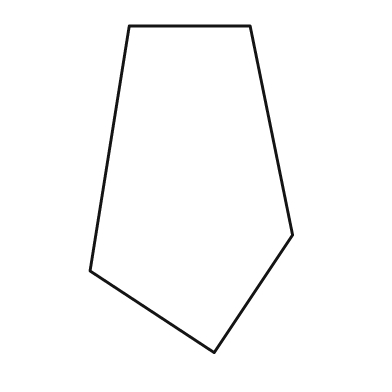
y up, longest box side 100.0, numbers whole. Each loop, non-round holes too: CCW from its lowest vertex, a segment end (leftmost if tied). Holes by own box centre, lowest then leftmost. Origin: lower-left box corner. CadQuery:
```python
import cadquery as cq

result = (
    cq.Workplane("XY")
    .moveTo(38.0, 0.0)
    .lineTo(62.0, 36.0)
    .lineTo(49.0, 100.0)
    .lineTo(12.0, 100.0)
    .lineTo(0.0, 25.0)
    .close()
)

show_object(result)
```